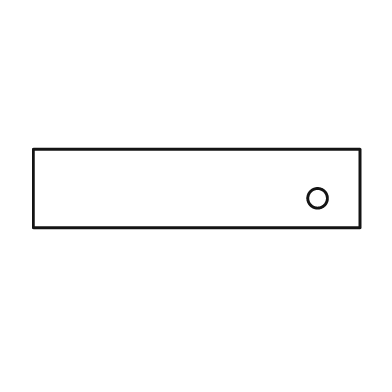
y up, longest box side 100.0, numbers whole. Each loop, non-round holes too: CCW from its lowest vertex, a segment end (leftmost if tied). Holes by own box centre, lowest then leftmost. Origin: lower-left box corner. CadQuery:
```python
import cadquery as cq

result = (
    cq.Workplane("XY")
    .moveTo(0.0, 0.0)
    .lineTo(100.0, 0.0)
    .lineTo(100.0, 24.0)
    .lineTo(0.0, 24.0)
    .close()
    .moveTo(87.0, 9.0)
    .circle(3.0)
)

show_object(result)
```